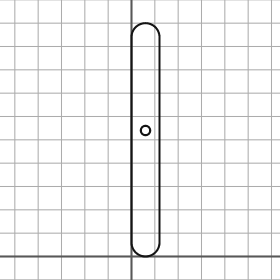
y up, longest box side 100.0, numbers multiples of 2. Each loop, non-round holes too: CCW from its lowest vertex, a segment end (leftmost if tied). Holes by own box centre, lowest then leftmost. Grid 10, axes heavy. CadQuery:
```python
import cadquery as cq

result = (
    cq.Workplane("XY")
    .moveTo(0.0, 6.0)
    .threePointArc((6.0, 0.0), (12.0, 6.0))
    .lineTo(12.0, 94.0)
    .threePointArc((6.0, 100.0), (0.0, 94.0))
    .close()
    .moveTo(6.0, 54.0)
    .circle(2.0)
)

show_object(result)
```